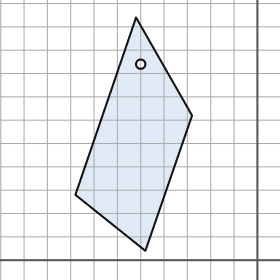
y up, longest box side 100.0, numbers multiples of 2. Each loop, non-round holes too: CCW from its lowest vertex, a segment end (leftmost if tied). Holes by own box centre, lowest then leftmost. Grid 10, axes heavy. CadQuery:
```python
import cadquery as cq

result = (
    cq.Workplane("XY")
    .moveTo(-48.0, 4.0)
    .lineTo(-28.0, 62.0)
    .lineTo(-52.0, 104.0)
    .lineTo(-78.0, 28.0)
    .close()
    .moveTo(-50.0, 84.0)
    .circle(2.0)
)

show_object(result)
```